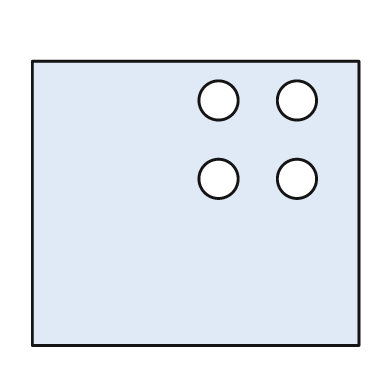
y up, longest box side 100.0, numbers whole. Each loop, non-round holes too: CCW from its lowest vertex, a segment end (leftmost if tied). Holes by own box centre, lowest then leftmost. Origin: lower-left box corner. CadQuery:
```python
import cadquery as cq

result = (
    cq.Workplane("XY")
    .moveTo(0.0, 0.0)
    .lineTo(100.0, 0.0)
    .lineTo(100.0, 87.0)
    .lineTo(0.0, 87.0)
    .close()
    .moveTo(57.0, 51.0)
    .circle(6.0)
    .moveTo(81.0, 51.0)
    .circle(6.0)
    .moveTo(57.0, 75.0)
    .circle(6.0)
    .moveTo(81.0, 75.0)
    .circle(6.0)
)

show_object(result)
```